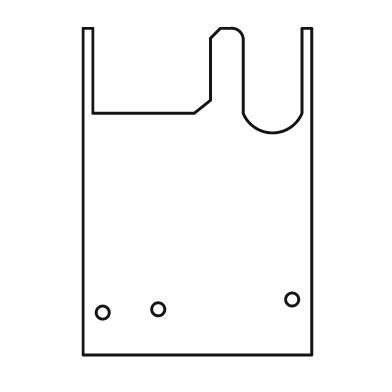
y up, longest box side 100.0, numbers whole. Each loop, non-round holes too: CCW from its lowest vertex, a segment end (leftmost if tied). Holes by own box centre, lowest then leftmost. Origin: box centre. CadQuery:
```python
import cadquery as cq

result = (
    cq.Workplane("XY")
    .moveTo(-35.0, -50.0)
    .lineTo(35.0, -50.0)
    .lineTo(35.0, 50.0)
    .lineTo(32.0, 50.0)
    .lineTo(32.0, 24.0)
    .threePointArc((23.0, 18.0), (14.0, 24.0))
    .lineTo(14.0, 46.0)
    .threePointArc((13.0, 49.0), (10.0, 50.0))
    .lineTo(7.0, 50.0)
    .lineTo(4.0, 47.0)
    .lineTo(4.0, 28.0)
    .lineTo(-1.0, 24.0)
    .lineTo(-32.0, 24.0)
    .lineTo(-32.0, 50.0)
    .lineTo(-35.0, 50.0)
    .close()
    .moveTo(-29.0, -37.0)
    .circle(2.0)
    .moveTo(-12.0, -36.0)
    .circle(2.0)
    .moveTo(29.0, -33.0)
    .circle(2.0)
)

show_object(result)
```